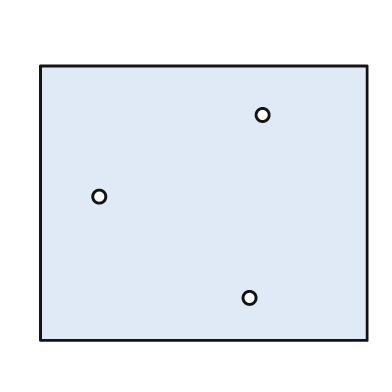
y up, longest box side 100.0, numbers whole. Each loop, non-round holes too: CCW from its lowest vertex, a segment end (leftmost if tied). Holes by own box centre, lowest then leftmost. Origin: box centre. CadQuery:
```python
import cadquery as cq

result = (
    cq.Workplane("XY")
    .moveTo(-50.0, -42.0)
    .lineTo(50.0, -42.0)
    .lineTo(50.0, 42.0)
    .lineTo(-50.0, 42.0)
    .close()
    .moveTo(14.0, -29.0)
    .circle(2.0)
    .moveTo(-32.0, 2.0)
    .circle(2.0)
    .moveTo(18.0, 27.0)
    .circle(2.0)
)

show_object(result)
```